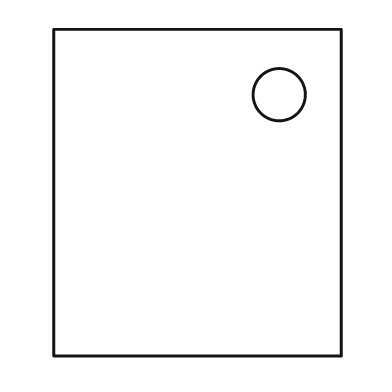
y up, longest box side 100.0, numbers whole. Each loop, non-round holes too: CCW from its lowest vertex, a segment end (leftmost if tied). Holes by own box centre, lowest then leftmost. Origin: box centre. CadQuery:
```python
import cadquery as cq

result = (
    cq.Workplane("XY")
    .moveTo(-44.0, -50.0)
    .lineTo(44.0, -50.0)
    .lineTo(44.0, 50.0)
    .lineTo(-44.0, 50.0)
    .close()
    .moveTo(25.0, 30.0)
    .circle(8.0)
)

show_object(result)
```